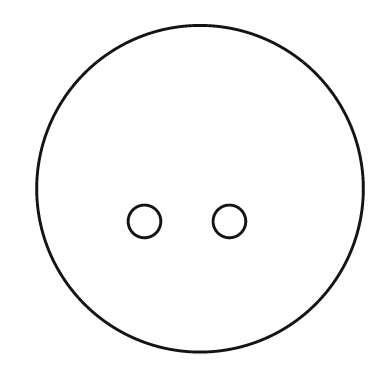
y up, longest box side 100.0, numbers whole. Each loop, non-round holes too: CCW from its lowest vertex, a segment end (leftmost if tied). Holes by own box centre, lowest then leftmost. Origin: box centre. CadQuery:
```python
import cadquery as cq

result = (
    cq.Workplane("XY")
    .moveTo(0.0, 0.0)
    .circle(50.0)
    .moveTo(-17.0, -10.0)
    .circle(5.0)
    .moveTo(9.0, -10.0)
    .circle(5.0)
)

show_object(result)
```